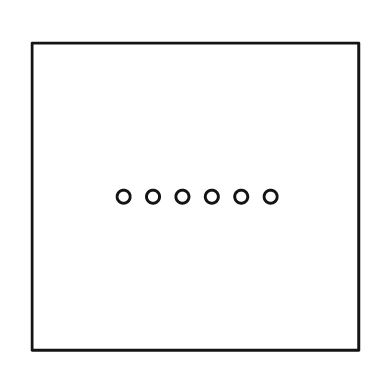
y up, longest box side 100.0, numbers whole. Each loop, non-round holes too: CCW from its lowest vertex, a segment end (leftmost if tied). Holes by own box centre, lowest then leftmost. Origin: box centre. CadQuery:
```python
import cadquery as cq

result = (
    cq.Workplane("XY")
    .moveTo(-50.0, -47.0)
    .lineTo(50.0, -47.0)
    .lineTo(50.0, 47.0)
    .lineTo(-50.0, 47.0)
    .close()
    .moveTo(-22.0, 0.0)
    .circle(2.0)
    .moveTo(-13.0, 0.0)
    .circle(2.0)
    .moveTo(-4.0, 0.0)
    .circle(2.0)
    .moveTo(5.0, 0.0)
    .circle(2.0)
    .moveTo(14.0, 0.0)
    .circle(2.0)
    .moveTo(23.0, 0.0)
    .circle(2.0)
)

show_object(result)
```